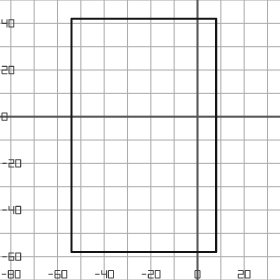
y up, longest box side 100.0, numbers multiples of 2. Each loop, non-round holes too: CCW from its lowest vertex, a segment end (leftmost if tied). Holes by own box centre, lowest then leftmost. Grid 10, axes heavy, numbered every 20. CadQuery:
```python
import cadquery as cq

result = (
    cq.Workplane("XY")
    .moveTo(-54.0, -58.0)
    .lineTo(8.0, -58.0)
    .lineTo(8.0, 42.0)
    .lineTo(-54.0, 42.0)
    .close()
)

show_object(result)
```